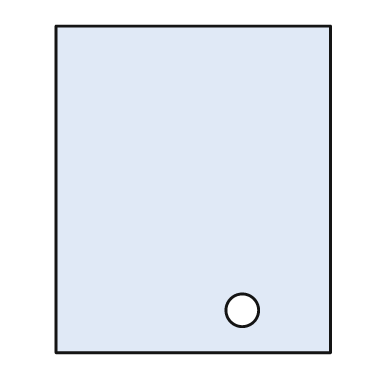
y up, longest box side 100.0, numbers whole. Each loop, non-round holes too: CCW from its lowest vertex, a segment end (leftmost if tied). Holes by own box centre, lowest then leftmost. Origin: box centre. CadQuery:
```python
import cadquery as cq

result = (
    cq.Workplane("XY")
    .moveTo(-42.0, -50.0)
    .lineTo(42.0, -50.0)
    .lineTo(42.0, 50.0)
    .lineTo(-42.0, 50.0)
    .close()
    .moveTo(15.0, -37.0)
    .circle(5.0)
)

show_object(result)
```